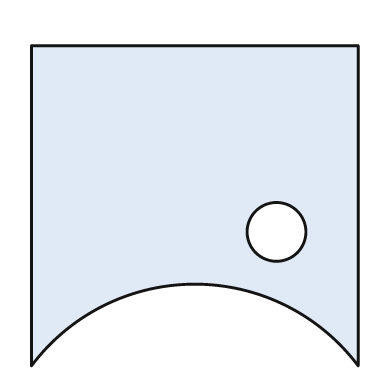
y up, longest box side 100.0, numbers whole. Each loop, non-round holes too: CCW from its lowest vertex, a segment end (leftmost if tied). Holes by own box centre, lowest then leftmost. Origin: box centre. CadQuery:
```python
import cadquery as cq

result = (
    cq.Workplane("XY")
    .moveTo(-50.0, -49.0)
    .threePointArc((0.0, -24.0), (50.0, -49.0))
    .lineTo(50.0, 49.0)
    .lineTo(-50.0, 49.0)
    .close()
    .moveTo(25.0, -8.0)
    .circle(9.0)
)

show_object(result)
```